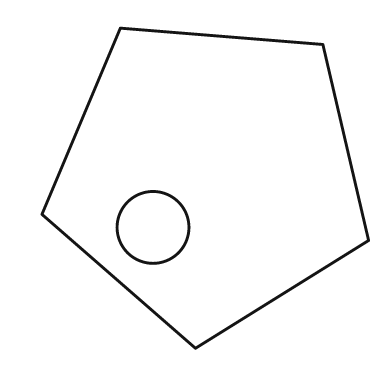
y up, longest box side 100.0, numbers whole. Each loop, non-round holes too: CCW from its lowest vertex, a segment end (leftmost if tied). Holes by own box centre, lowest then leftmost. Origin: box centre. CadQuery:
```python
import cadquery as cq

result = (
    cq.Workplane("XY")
    .moveTo(-3.0, -49.0)
    .lineTo(50.0, -16.0)
    .lineTo(36.0, 44.0)
    .lineTo(-26.0, 49.0)
    .lineTo(-50.0, -8.0)
    .close()
    .moveTo(-16.0, -12.0)
    .circle(11.0)
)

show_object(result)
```